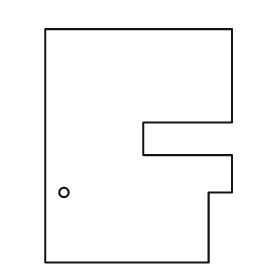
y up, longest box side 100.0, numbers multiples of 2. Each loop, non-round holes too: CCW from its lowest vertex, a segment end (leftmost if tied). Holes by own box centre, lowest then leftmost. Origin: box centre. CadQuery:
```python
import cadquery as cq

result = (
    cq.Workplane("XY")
    .moveTo(-40.0, -50.0)
    .lineTo(30.0, -50.0)
    .lineTo(30.0, -20.0)
    .lineTo(40.0, -20.0)
    .lineTo(40.0, -4.0)
    .lineTo(2.0, -4.0)
    .lineTo(2.0, 10.0)
    .lineTo(40.0, 10.0)
    .lineTo(40.0, 50.0)
    .lineTo(-40.0, 50.0)
    .close()
    .moveTo(-32.0, -20.0)
    .circle(2.0)
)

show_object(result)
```